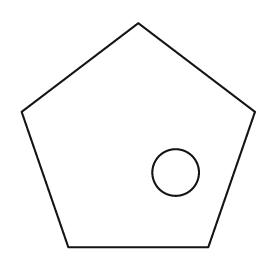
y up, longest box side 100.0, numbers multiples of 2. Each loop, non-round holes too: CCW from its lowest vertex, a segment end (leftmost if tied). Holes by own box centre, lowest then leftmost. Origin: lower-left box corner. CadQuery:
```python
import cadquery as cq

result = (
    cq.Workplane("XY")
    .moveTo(20.0, 0.0)
    .lineTo(80.0, 0.0)
    .lineTo(100.0, 58.0)
    .lineTo(50.0, 96.0)
    .lineTo(0.0, 58.0)
    .close()
    .moveTo(66.0, 32.0)
    .circle(10.0)
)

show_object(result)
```